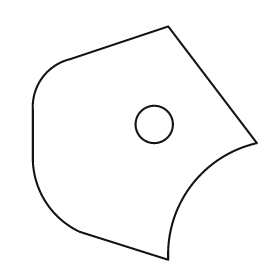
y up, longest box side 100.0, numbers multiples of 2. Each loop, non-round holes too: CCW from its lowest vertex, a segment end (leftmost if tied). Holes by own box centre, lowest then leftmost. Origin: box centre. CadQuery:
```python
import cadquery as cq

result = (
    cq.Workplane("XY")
    .moveTo(10.0, -50.0)
    .threePointArc((20.0, -18.0), (48.0, 0.0))
    .lineTo(10.0, 50.0)
    .lineTo(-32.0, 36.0)
    .threePointArc((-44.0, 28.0), (-48.0, 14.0))
    .lineTo(-48.0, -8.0)
    .threePointArc((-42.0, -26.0), (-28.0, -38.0))
    .close()
    .moveTo(4.0, 8.0)
    .circle(8.0)
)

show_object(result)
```